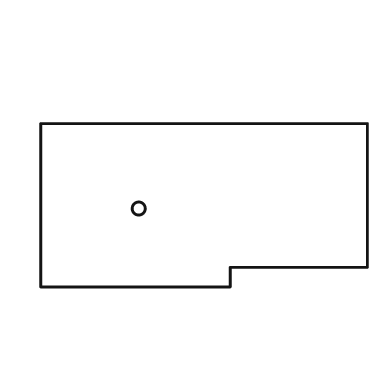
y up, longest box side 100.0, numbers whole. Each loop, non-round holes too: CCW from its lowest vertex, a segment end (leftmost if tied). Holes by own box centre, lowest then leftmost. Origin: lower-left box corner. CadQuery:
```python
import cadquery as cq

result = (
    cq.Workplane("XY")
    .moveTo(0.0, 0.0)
    .lineTo(58.0, 0.0)
    .lineTo(58.0, 6.0)
    .lineTo(100.0, 6.0)
    .lineTo(100.0, 50.0)
    .lineTo(0.0, 50.0)
    .close()
    .moveTo(30.0, 24.0)
    .circle(2.0)
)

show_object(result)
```